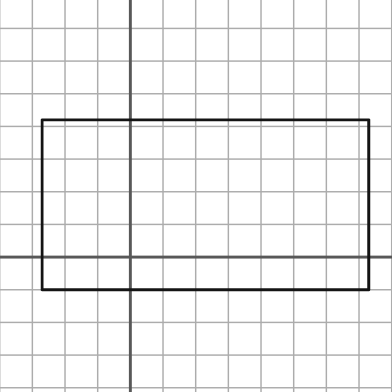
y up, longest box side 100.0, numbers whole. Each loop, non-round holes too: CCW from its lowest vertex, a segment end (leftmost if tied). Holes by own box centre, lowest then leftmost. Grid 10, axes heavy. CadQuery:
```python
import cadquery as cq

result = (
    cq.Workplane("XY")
    .moveTo(-27.0, -10.0)
    .lineTo(73.0, -10.0)
    .lineTo(73.0, 42.0)
    .lineTo(-27.0, 42.0)
    .close()
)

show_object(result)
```